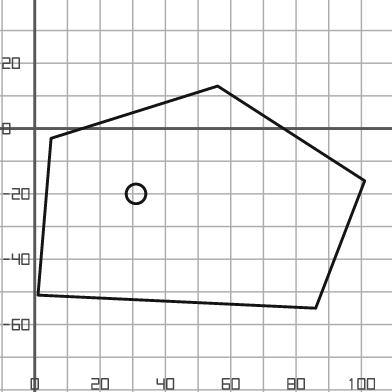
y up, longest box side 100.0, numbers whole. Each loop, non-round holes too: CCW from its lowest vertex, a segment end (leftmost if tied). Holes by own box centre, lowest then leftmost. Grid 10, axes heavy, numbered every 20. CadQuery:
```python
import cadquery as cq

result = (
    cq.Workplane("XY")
    .moveTo(86.0, -55.0)
    .lineTo(101.0, -16.0)
    .lineTo(56.0, 13.0)
    .lineTo(5.0, -3.0)
    .lineTo(1.0, -51.0)
    .close()
    .moveTo(31.0, -20.0)
    .circle(3.0)
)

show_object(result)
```